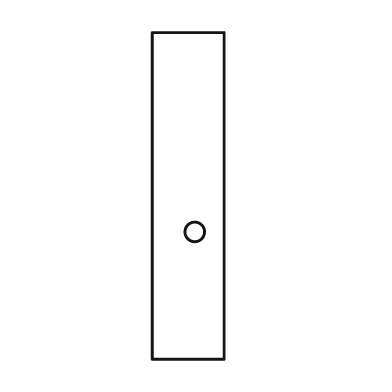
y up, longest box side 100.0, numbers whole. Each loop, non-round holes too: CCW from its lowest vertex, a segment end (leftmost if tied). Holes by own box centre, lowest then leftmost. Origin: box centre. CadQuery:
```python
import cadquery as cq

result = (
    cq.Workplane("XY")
    .moveTo(-11.0, -50.0)
    .lineTo(11.0, -50.0)
    .lineTo(11.0, 50.0)
    .lineTo(-11.0, 50.0)
    .close()
    .moveTo(2.0, -11.0)
    .circle(3.0)
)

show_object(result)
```